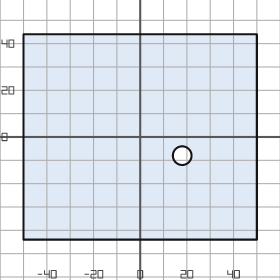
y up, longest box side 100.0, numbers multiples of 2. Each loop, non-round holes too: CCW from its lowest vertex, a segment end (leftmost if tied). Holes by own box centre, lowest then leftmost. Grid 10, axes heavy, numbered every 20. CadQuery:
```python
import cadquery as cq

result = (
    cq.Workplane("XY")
    .moveTo(-50.0, -44.0)
    .lineTo(50.0, -44.0)
    .lineTo(50.0, 44.0)
    .lineTo(-50.0, 44.0)
    .close()
    .moveTo(18.0, -8.0)
    .circle(4.0)
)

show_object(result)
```